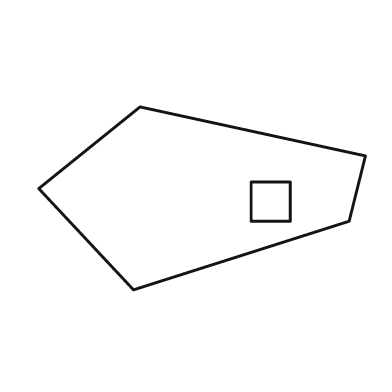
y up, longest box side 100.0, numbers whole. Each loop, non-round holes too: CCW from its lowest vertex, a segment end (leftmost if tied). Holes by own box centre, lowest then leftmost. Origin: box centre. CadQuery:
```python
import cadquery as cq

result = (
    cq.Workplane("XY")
    .moveTo(-21.0, -28.0)
    .lineTo(45.0, -7.0)
    .lineTo(50.0, 13.0)
    .lineTo(-19.0, 28.0)
    .lineTo(-50.0, 3.0)
    .close()
    .moveTo(15.0, -7.0)
    .lineTo(27.0, -7.0)
    .lineTo(27.0, 5.0)
    .lineTo(15.0, 5.0)
    .close()
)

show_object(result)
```